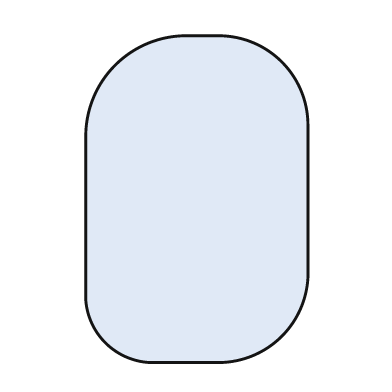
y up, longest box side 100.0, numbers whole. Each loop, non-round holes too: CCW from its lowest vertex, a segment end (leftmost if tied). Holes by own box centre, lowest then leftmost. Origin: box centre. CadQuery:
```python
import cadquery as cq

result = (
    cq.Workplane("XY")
    .moveTo(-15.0, -50.0)
    .lineTo(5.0, -50.0)
    .threePointArc((26.0, -42.0), (34.0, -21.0))
    .lineTo(34.0, 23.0)
    .threePointArc((26.0, 42.0), (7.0, 50.0))
    .lineTo(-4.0, 50.0)
    .threePointArc((-25.0, 41.0), (-34.0, 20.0))
    .lineTo(-34.0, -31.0)
    .threePointArc((-28.0, -44.0), (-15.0, -50.0))
    .close()
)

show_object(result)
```